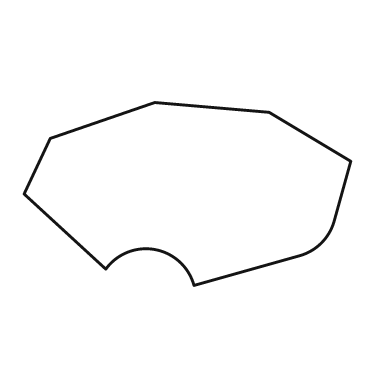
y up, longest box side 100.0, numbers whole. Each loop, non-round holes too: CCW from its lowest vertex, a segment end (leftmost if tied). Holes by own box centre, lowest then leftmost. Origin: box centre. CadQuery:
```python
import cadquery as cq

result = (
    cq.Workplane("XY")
    .moveTo(2.0, -28.0)
    .lineTo(34.0, -19.0)
    .threePointArc((41.0, -15.0), (45.0, -8.0))
    .lineTo(50.0, 10.0)
    .lineTo(25.0, 25.0)
    .lineTo(-10.0, 28.0)
    .lineTo(-42.0, 17.0)
    .lineTo(-50.0, 0.0)
    .lineTo(-25.0, -23.0)
    .threePointArc((-10.0, -17.0), (2.0, -28.0))
    .close()
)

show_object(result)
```